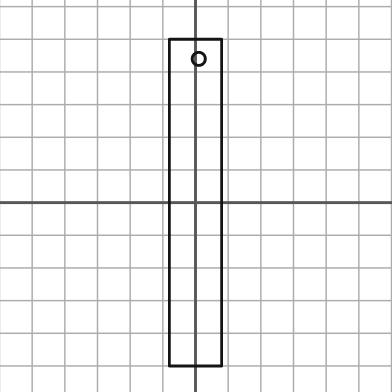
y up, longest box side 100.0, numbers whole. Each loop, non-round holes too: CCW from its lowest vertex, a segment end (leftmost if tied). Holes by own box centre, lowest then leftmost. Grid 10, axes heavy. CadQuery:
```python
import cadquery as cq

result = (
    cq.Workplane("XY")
    .moveTo(-8.0, -50.0)
    .lineTo(8.0, -50.0)
    .lineTo(8.0, 50.0)
    .lineTo(-8.0, 50.0)
    .close()
    .moveTo(1.0, 44.0)
    .circle(2.0)
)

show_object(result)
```